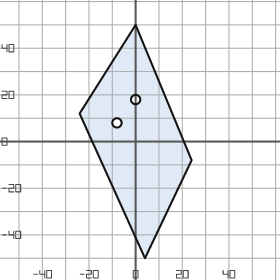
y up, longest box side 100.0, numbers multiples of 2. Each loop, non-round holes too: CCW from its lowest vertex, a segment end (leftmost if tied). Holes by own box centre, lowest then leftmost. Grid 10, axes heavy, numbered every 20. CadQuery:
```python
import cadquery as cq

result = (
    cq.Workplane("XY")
    .moveTo(4.0, -50.0)
    .lineTo(24.0, -8.0)
    .lineTo(0.0, 50.0)
    .lineTo(-24.0, 12.0)
    .close()
    .moveTo(-8.0, 8.0)
    .circle(2.0)
    .moveTo(0.0, 18.0)
    .circle(2.0)
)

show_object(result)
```